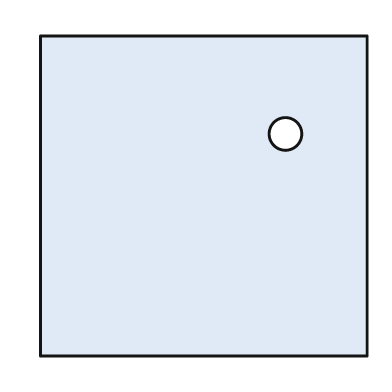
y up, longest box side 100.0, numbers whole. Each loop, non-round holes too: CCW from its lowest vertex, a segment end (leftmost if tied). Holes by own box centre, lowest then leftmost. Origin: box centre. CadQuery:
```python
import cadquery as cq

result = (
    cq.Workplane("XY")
    .moveTo(-50.0, -49.0)
    .lineTo(50.0, -49.0)
    .lineTo(50.0, 49.0)
    .lineTo(-50.0, 49.0)
    .close()
    .moveTo(25.0, 19.0)
    .circle(5.0)
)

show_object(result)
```